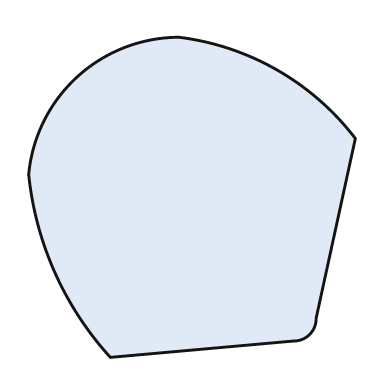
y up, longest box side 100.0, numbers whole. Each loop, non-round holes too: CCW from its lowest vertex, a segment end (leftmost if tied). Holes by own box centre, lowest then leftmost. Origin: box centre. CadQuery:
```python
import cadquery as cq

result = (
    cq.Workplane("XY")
    .moveTo(-25.0, -49.0)
    .lineTo(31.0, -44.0)
    .threePointArc((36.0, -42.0), (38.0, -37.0))
    .lineTo(50.0, 18.0)
    .threePointArc((26.0, 39.0), (-4.0, 49.0))
    .threePointArc((-35.0, 37.0), (-50.0, 7.0))
    .threePointArc((-42.0, -23.0), (-25.0, -49.0))
    .close()
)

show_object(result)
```